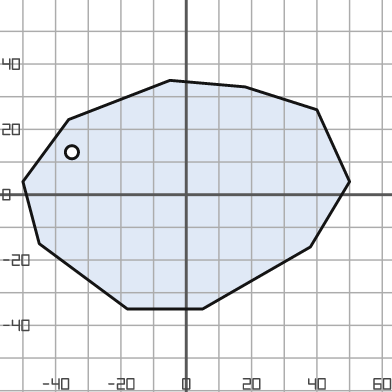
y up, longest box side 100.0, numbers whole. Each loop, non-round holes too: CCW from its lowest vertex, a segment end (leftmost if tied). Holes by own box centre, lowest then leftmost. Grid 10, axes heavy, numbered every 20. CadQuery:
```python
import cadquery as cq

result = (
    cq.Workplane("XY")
    .moveTo(-18.0, -35.0)
    .lineTo(5.0, -35.0)
    .lineTo(38.0, -16.0)
    .lineTo(50.0, 4.0)
    .lineTo(40.0, 26.0)
    .lineTo(18.0, 33.0)
    .lineTo(-5.0, 35.0)
    .lineTo(-36.0, 23.0)
    .lineTo(-50.0, 4.0)
    .lineTo(-45.0, -15.0)
    .close()
    .moveTo(-35.0, 13.0)
    .circle(2.0)
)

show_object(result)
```